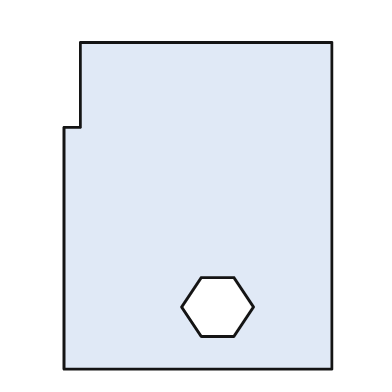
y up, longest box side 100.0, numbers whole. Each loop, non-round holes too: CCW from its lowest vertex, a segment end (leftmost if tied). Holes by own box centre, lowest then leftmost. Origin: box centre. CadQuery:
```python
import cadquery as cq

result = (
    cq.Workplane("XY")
    .moveTo(-41.0, -50.0)
    .lineTo(41.0, -50.0)
    .lineTo(41.0, 50.0)
    .lineTo(-36.0, 50.0)
    .lineTo(-36.0, 24.0)
    .lineTo(-41.0, 24.0)
    .close()
    .moveTo(1.0, -40.0)
    .lineTo(11.0, -40.0)
    .lineTo(17.0, -31.0)
    .lineTo(11.0, -22.0)
    .lineTo(1.0, -22.0)
    .lineTo(-5.0, -31.0)
    .close()
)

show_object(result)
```